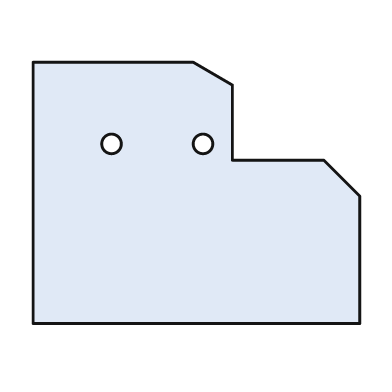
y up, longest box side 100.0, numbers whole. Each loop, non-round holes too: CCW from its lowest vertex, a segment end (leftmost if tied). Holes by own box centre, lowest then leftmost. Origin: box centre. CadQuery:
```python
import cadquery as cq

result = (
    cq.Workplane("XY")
    .moveTo(-50.0, -40.0)
    .lineTo(50.0, -40.0)
    .lineTo(50.0, -1.0)
    .lineTo(39.0, 10.0)
    .lineTo(11.0, 10.0)
    .lineTo(11.0, 33.0)
    .lineTo(-1.0, 40.0)
    .lineTo(-50.0, 40.0)
    .close()
    .moveTo(-26.0, 15.0)
    .circle(3.0)
    .moveTo(2.0, 15.0)
    .circle(3.0)
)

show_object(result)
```